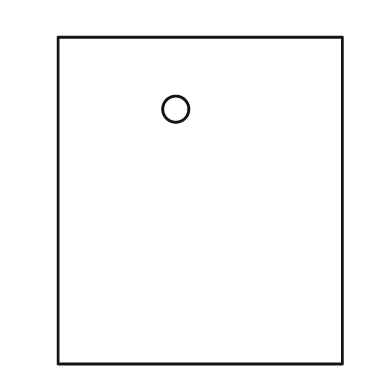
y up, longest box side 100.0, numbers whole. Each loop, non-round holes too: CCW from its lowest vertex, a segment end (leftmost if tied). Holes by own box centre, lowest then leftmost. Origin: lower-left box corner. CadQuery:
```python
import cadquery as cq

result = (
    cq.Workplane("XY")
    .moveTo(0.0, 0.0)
    .lineTo(87.0, 0.0)
    .lineTo(87.0, 100.0)
    .lineTo(0.0, 100.0)
    .close()
    .moveTo(36.0, 78.0)
    .circle(4.0)
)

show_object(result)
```